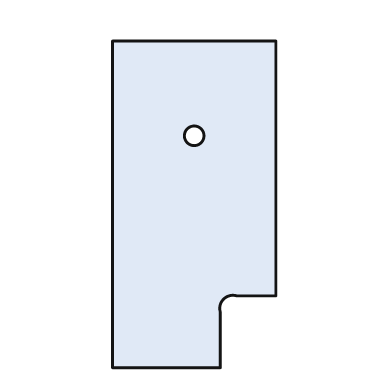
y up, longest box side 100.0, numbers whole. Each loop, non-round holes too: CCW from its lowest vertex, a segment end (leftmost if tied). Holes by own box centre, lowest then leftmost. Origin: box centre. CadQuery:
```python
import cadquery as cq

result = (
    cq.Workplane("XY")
    .moveTo(-25.0, -50.0)
    .lineTo(8.0, -50.0)
    .lineTo(8.0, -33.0)
    .threePointArc((9.0, -29.0), (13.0, -28.0))
    .lineTo(25.0, -28.0)
    .lineTo(25.0, 50.0)
    .lineTo(-25.0, 50.0)
    .close()
    .moveTo(0.0, 21.0)
    .circle(3.0)
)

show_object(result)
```